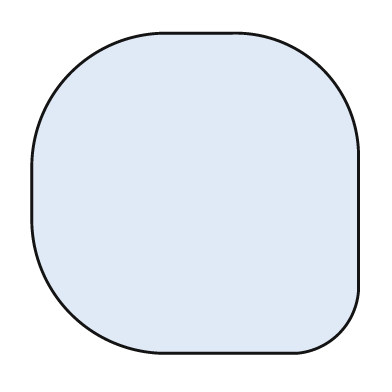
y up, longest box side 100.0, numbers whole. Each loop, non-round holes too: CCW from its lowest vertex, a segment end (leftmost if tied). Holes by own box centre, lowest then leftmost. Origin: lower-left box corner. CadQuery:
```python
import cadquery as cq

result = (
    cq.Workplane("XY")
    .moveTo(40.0, 0.0)
    .lineTo(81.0, 0.0)
    .threePointArc((94.0, 6.0), (100.0, 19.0))
    .lineTo(100.0, 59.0)
    .threePointArc((89.0, 87.0), (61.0, 98.0))
    .lineTo(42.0, 98.0)
    .threePointArc((12.0, 86.0), (0.0, 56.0))
    .lineTo(0.0, 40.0)
    .threePointArc((12.0, 12.0), (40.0, 0.0))
    .close()
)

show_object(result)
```